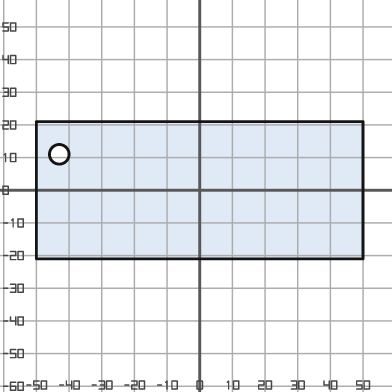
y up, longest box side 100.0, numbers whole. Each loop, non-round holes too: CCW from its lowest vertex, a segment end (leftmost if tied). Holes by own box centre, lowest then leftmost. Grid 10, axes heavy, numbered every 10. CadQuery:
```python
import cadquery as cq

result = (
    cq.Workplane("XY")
    .moveTo(-50.0, -21.0)
    .lineTo(50.0, -21.0)
    .lineTo(50.0, 21.0)
    .lineTo(-50.0, 21.0)
    .close()
    .moveTo(-43.0, 11.0)
    .circle(3.0)
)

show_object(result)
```